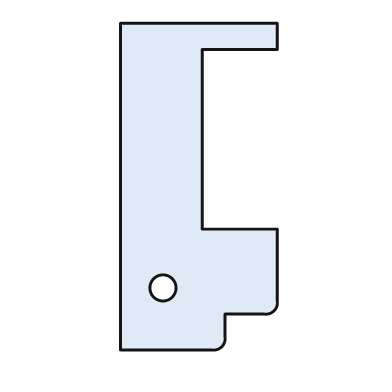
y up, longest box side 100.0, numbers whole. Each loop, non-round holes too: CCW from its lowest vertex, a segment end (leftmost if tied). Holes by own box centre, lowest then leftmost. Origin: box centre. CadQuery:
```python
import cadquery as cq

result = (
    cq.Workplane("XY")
    .moveTo(-24.0, -50.0)
    .lineTo(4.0, -50.0)
    .threePointArc((7.0, -49.0), (8.0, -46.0))
    .lineTo(8.0, -39.0)
    .lineTo(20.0, -39.0)
    .threePointArc((23.0, -38.0), (24.0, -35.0))
    .lineTo(24.0, -13.0)
    .lineTo(1.0, -13.0)
    .lineTo(1.0, 42.0)
    .lineTo(24.0, 42.0)
    .lineTo(24.0, 50.0)
    .lineTo(-24.0, 50.0)
    .close()
    .moveTo(-11.0, -31.0)
    .circle(4.0)
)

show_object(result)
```